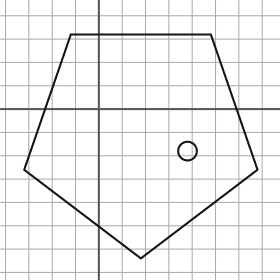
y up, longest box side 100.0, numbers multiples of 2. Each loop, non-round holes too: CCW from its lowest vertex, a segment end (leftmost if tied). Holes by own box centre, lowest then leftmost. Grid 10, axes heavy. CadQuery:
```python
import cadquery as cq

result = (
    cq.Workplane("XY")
    .moveTo(18.0, -64.0)
    .lineTo(68.0, -26.0)
    .lineTo(48.0, 32.0)
    .lineTo(-12.0, 32.0)
    .lineTo(-32.0, -26.0)
    .close()
    .moveTo(38.0, -18.0)
    .circle(4.0)
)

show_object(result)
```